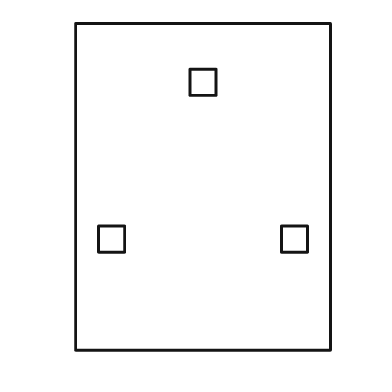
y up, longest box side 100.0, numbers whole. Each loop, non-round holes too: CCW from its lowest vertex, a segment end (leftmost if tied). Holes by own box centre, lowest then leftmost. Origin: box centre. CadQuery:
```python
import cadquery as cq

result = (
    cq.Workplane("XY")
    .moveTo(-39.0, -50.0)
    .lineTo(39.0, -50.0)
    .lineTo(39.0, 50.0)
    .lineTo(-39.0, 50.0)
    .close()
    .moveTo(-32.0, -20.0)
    .lineTo(-24.0, -20.0)
    .lineTo(-24.0, -12.0)
    .lineTo(-32.0, -12.0)
    .close()
    .moveTo(24.0, -20.0)
    .lineTo(32.0, -20.0)
    .lineTo(32.0, -12.0)
    .lineTo(24.0, -12.0)
    .close()
    .moveTo(-4.0, 28.0)
    .lineTo(4.0, 28.0)
    .lineTo(4.0, 36.0)
    .lineTo(-4.0, 36.0)
    .close()
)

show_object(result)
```